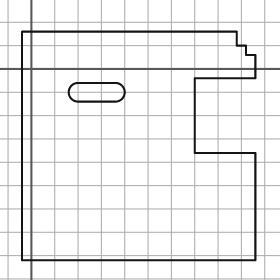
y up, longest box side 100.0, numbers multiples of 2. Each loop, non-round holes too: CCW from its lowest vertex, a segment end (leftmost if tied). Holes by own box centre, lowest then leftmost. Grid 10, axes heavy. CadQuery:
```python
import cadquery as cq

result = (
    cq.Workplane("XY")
    .moveTo(-4.0, -82.0)
    .lineTo(96.0, -82.0)
    .lineTo(96.0, -36.0)
    .lineTo(70.0, -36.0)
    .lineTo(70.0, -4.0)
    .lineTo(96.0, -4.0)
    .lineTo(96.0, 6.0)
    .lineTo(92.0, 6.0)
    .lineTo(92.0, 10.0)
    .lineTo(88.0, 10.0)
    .lineTo(88.0, 16.0)
    .lineTo(-4.0, 16.0)
    .close()
    .moveTo(20.0, -14.0)
    .lineTo(36.0, -14.0)
    .threePointArc((40.0, -10.0), (36.0, -6.0))
    .lineTo(20.0, -6.0)
    .threePointArc((16.0, -10.0), (20.0, -14.0))
    .close()
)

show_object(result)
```